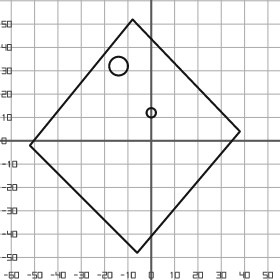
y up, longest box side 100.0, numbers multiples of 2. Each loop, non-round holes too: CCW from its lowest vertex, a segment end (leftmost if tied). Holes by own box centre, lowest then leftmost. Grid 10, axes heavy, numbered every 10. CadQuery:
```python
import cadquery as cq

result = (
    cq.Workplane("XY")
    .moveTo(-6.0, -48.0)
    .lineTo(38.0, 4.0)
    .lineTo(-8.0, 52.0)
    .lineTo(-52.0, -2.0)
    .close()
    .moveTo(0.0, 12.0)
    .circle(2.0)
    .moveTo(-14.0, 32.0)
    .circle(4.0)
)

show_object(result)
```